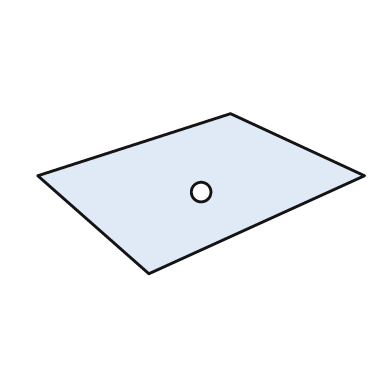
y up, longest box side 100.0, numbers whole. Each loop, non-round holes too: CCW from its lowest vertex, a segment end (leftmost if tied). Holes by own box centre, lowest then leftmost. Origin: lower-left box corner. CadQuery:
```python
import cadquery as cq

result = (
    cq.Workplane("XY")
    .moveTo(34.0, 0.0)
    .lineTo(100.0, 30.0)
    .lineTo(59.0, 49.0)
    .lineTo(0.0, 30.0)
    .close()
    .moveTo(50.0, 25.0)
    .circle(3.0)
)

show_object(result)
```